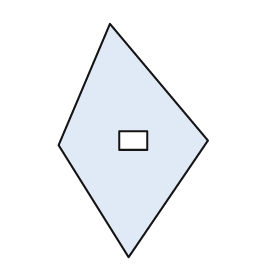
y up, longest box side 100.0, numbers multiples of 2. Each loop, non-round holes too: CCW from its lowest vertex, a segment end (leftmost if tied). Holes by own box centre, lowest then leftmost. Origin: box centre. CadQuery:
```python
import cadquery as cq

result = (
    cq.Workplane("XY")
    .moveTo(-2.0, -50.0)
    .lineTo(32.0, 0.0)
    .lineTo(-10.0, 50.0)
    .lineTo(-32.0, -2.0)
    .close()
    .moveTo(-6.0, -4.0)
    .lineTo(6.0, -4.0)
    .lineTo(6.0, 4.0)
    .lineTo(-6.0, 4.0)
    .close()
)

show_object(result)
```